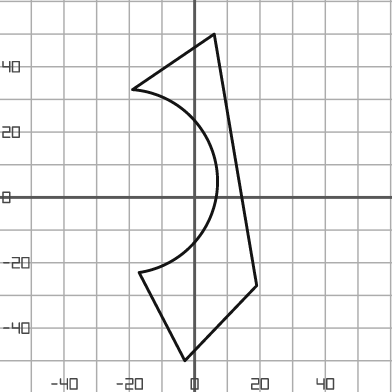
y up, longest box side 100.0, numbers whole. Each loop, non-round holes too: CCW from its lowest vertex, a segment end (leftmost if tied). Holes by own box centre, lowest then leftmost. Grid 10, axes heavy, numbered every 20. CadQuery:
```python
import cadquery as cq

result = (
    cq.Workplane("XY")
    .moveTo(-3.0, -50.0)
    .lineTo(19.0, -27.0)
    .lineTo(6.0, 50.0)
    .lineTo(-19.0, 33.0)
    .threePointArc((7.0, 6.0), (-17.0, -23.0))
    .close()
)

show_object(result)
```